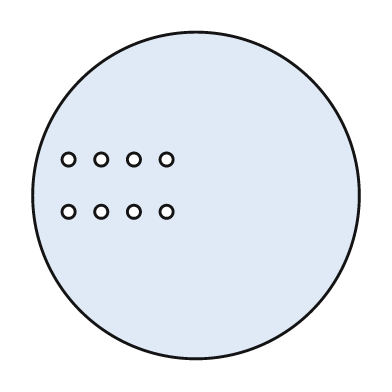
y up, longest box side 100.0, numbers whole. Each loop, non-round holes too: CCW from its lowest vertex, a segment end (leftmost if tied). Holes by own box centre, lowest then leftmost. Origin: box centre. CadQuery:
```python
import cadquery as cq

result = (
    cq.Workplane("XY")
    .moveTo(0.0, 0.0)
    .circle(50.0)
    .moveTo(-39.0, -5.0)
    .circle(2.0)
    .moveTo(-29.0, -5.0)
    .circle(2.0)
    .moveTo(-19.0, -5.0)
    .circle(2.0)
    .moveTo(-9.0, -5.0)
    .circle(2.0)
    .moveTo(-39.0, 11.0)
    .circle(2.0)
    .moveTo(-29.0, 11.0)
    .circle(2.0)
    .moveTo(-19.0, 11.0)
    .circle(2.0)
    .moveTo(-9.0, 11.0)
    .circle(2.0)
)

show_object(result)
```